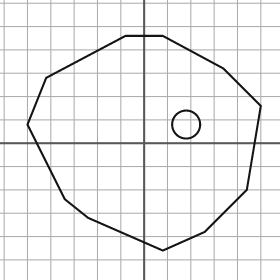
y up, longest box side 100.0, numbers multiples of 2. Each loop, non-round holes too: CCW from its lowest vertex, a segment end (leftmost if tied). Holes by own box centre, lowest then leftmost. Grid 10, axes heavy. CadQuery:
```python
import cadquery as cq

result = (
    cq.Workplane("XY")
    .moveTo(8.0, -46.0)
    .lineTo(26.0, -38.0)
    .lineTo(44.0, -20.0)
    .lineTo(50.0, 16.0)
    .lineTo(34.0, 32.0)
    .lineTo(8.0, 46.0)
    .lineTo(-8.0, 46.0)
    .lineTo(-42.0, 28.0)
    .lineTo(-50.0, 8.0)
    .lineTo(-34.0, -24.0)
    .lineTo(-24.0, -32.0)
    .close()
    .moveTo(18.0, 8.0)
    .circle(6.0)
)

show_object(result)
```